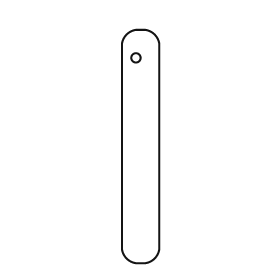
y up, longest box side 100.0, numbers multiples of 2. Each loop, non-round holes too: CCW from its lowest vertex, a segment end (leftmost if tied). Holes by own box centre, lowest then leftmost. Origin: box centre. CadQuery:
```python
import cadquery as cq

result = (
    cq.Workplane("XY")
    .moveTo(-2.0, -50.0)
    .lineTo(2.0, -50.0)
    .threePointArc((6.0, -48.0), (8.0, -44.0))
    .lineTo(8.0, 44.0)
    .threePointArc((6.0, 48.0), (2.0, 50.0))
    .lineTo(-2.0, 50.0)
    .threePointArc((-6.0, 48.0), (-8.0, 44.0))
    .lineTo(-8.0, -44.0)
    .threePointArc((-6.0, -48.0), (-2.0, -50.0))
    .close()
    .moveTo(-2.0, 38.0)
    .circle(2.0)
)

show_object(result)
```